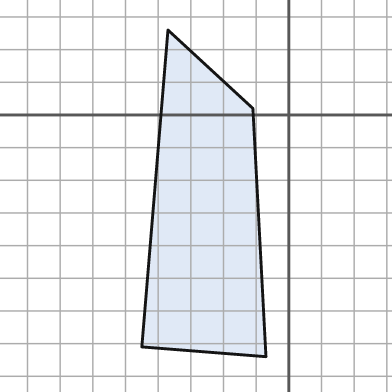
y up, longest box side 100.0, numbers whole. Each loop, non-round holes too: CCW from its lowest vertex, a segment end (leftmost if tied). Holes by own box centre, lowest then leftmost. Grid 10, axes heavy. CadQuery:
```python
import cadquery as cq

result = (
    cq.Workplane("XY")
    .moveTo(-7.0, -74.0)
    .lineTo(-11.0, 2.0)
    .lineTo(-37.0, 26.0)
    .lineTo(-45.0, -71.0)
    .close()
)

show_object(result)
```